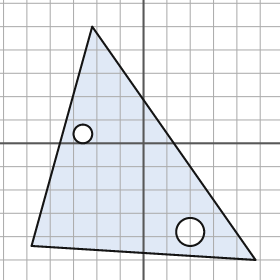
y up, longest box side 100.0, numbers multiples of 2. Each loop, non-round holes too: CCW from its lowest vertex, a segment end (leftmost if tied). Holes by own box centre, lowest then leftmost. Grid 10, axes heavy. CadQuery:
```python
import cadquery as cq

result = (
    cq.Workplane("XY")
    .moveTo(48.0, -50.0)
    .lineTo(-22.0, 50.0)
    .lineTo(-48.0, -44.0)
    .close()
    .moveTo(20.0, -38.0)
    .circle(6.0)
    .moveTo(-26.0, 4.0)
    .circle(4.0)
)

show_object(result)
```